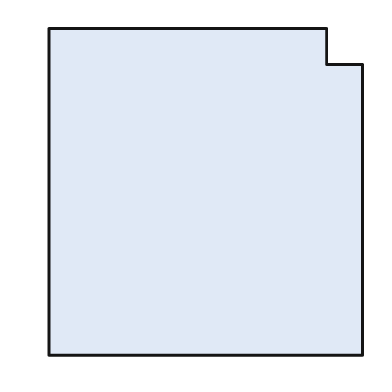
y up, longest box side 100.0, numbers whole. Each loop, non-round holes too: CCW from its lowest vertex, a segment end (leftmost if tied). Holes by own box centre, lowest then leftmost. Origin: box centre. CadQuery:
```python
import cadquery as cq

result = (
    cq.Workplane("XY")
    .moveTo(-48.0, -50.0)
    .lineTo(48.0, -50.0)
    .lineTo(48.0, 39.0)
    .lineTo(37.0, 39.0)
    .lineTo(37.0, 50.0)
    .lineTo(-48.0, 50.0)
    .close()
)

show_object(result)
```